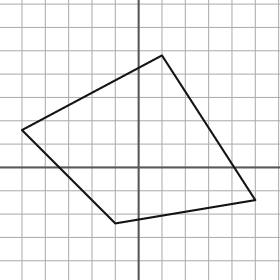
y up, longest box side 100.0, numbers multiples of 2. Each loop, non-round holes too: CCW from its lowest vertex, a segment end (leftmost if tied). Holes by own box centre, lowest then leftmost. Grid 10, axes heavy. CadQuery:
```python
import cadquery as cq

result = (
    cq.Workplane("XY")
    .moveTo(-10.0, -24.0)
    .lineTo(50.0, -14.0)
    .lineTo(10.0, 48.0)
    .lineTo(-50.0, 16.0)
    .close()
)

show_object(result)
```